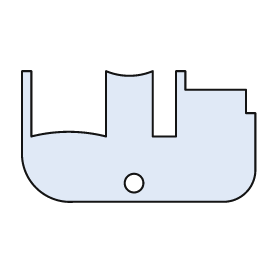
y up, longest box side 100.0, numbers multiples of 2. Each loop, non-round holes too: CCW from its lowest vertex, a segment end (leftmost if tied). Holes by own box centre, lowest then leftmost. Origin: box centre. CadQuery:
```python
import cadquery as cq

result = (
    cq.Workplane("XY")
    .moveTo(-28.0, -28.0)
    .lineTo(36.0, -28.0)
    .threePointArc((46.0, -24.0), (50.0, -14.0))
    .lineTo(50.0, 10.0)
    .lineTo(46.0, 10.0)
    .lineTo(46.0, 20.0)
    .lineTo(20.0, 20.0)
    .lineTo(20.0, 28.0)
    .lineTo(16.0, 28.0)
    .lineTo(16.0, 0.0)
    .lineTo(6.0, 0.0)
    .lineTo(6.0, 28.0)
    .threePointArc((-4.0, 26.0), (-14.0, 28.0))
    .lineTo(-14.0, 0.0)
    .threePointArc((-30.0, 2.0), (-46.0, 0.0))
    .lineTo(-46.0, 28.0)
    .lineTo(-50.0, 28.0)
    .lineTo(-50.0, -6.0)
    .threePointArc((-44.0, -22.0), (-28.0, -28.0))
    .close()
    .moveTo(-2.0, -20.0)
    .circle(4.0)
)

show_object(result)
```